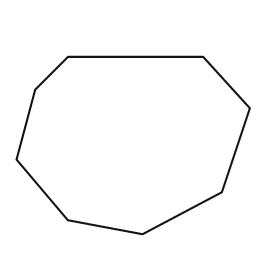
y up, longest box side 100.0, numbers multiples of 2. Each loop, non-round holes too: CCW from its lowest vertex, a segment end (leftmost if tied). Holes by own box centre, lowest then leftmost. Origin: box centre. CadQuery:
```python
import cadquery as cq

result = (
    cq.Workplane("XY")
    .moveTo(4.0, -38.0)
    .lineTo(38.0, -20.0)
    .lineTo(50.0, 16.0)
    .lineTo(30.0, 38.0)
    .lineTo(-28.0, 38.0)
    .lineTo(-42.0, 24.0)
    .lineTo(-50.0, -6.0)
    .lineTo(-28.0, -32.0)
    .close()
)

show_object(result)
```